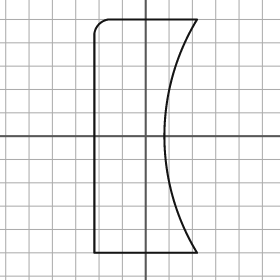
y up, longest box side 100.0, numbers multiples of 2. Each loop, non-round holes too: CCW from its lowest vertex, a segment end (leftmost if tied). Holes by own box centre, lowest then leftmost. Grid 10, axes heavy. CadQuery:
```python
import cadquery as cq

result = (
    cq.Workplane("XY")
    .moveTo(-22.0, -50.0)
    .lineTo(22.0, -50.0)
    .threePointArc((8.0, 0.0), (22.0, 50.0))
    .lineTo(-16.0, 50.0)
    .threePointArc((-20.0, 48.0), (-22.0, 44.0))
    .close()
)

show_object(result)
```